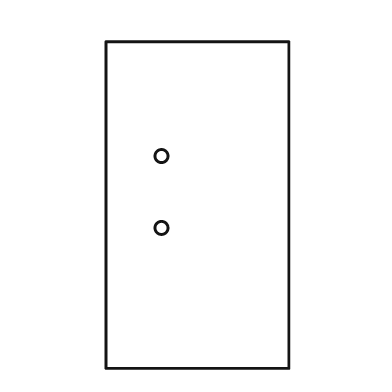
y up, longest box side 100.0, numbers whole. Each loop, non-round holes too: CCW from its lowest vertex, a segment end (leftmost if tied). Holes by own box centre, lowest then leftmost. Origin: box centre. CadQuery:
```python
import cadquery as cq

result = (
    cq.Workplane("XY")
    .moveTo(-28.0, -50.0)
    .lineTo(28.0, -50.0)
    .lineTo(28.0, 50.0)
    .lineTo(-28.0, 50.0)
    .close()
    .moveTo(-11.0, -7.0)
    .circle(2.0)
    .moveTo(-11.0, 15.0)
    .circle(2.0)
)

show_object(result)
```